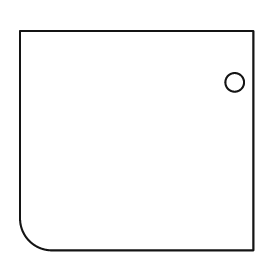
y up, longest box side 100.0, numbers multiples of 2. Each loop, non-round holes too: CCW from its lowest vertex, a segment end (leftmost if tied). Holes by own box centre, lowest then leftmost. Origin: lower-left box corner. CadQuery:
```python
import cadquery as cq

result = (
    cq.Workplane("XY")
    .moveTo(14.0, 0.0)
    .lineTo(100.0, 0.0)
    .lineTo(100.0, 94.0)
    .lineTo(0.0, 94.0)
    .lineTo(0.0, 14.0)
    .threePointArc((4.0, 4.0), (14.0, 0.0))
    .close()
    .moveTo(92.0, 72.0)
    .circle(4.0)
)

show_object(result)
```